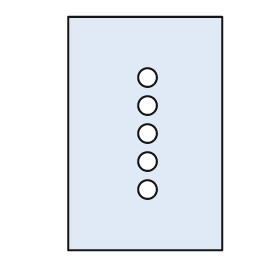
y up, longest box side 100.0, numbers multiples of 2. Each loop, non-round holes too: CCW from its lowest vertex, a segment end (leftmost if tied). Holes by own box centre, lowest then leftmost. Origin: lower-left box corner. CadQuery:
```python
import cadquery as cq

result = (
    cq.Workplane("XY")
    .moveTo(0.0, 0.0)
    .lineTo(66.0, 0.0)
    .lineTo(66.0, 100.0)
    .lineTo(0.0, 100.0)
    .close()
    .moveTo(34.0, 26.0)
    .circle(4.0)
    .moveTo(34.0, 38.0)
    .circle(4.0)
    .moveTo(34.0, 50.0)
    .circle(4.0)
    .moveTo(34.0, 62.0)
    .circle(4.0)
    .moveTo(34.0, 74.0)
    .circle(4.0)
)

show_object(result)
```